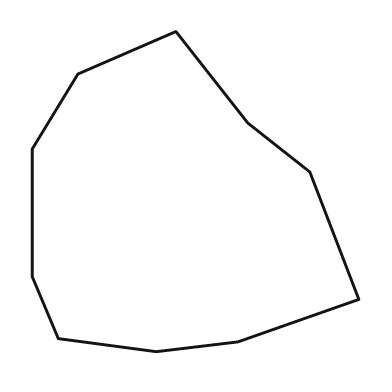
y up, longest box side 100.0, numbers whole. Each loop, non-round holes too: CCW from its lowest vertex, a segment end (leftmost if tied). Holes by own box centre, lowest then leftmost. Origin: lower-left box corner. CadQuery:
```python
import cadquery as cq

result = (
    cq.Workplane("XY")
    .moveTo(38.0, 0.0)
    .lineTo(63.0, 3.0)
    .lineTo(100.0, 16.0)
    .lineTo(85.0, 55.0)
    .lineTo(66.0, 70.0)
    .lineTo(44.0, 98.0)
    .lineTo(14.0, 85.0)
    .lineTo(0.0, 62.0)
    .lineTo(0.0, 23.0)
    .lineTo(8.0, 4.0)
    .close()
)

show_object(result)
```